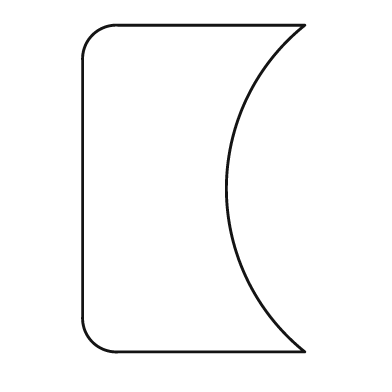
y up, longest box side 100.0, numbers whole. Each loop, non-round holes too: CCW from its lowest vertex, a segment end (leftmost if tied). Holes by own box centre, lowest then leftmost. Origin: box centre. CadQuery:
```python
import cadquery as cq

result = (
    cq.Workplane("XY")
    .moveTo(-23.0, -50.0)
    .lineTo(34.0, -50.0)
    .threePointArc((10.0, 0.0), (34.0, 50.0))
    .lineTo(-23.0, 50.0)
    .threePointArc((-31.0, 47.0), (-34.0, 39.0))
    .lineTo(-34.0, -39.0)
    .threePointArc((-31.0, -47.0), (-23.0, -50.0))
    .close()
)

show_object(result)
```